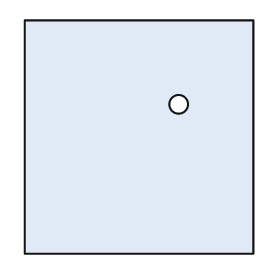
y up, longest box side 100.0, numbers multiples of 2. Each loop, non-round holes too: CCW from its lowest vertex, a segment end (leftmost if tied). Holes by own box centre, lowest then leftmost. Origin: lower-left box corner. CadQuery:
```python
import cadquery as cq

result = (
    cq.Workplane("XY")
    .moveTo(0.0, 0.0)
    .lineTo(98.0, 0.0)
    .lineTo(98.0, 100.0)
    .lineTo(0.0, 100.0)
    .close()
    .moveTo(66.0, 64.0)
    .circle(4.0)
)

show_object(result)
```